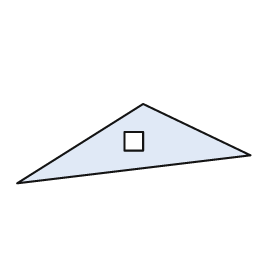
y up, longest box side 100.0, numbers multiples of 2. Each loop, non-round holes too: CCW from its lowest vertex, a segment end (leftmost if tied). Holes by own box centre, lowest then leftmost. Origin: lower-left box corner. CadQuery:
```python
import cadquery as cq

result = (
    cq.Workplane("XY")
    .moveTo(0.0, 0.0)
    .lineTo(100.0, 12.0)
    .lineTo(54.0, 34.0)
    .close()
    .moveTo(46.0, 14.0)
    .lineTo(54.0, 14.0)
    .lineTo(54.0, 22.0)
    .lineTo(46.0, 22.0)
    .close()
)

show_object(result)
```